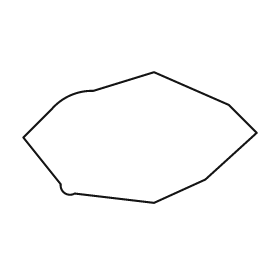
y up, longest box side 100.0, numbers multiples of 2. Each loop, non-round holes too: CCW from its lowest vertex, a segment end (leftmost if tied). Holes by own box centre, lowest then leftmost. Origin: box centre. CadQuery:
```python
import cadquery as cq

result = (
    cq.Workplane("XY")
    .moveTo(6.0, -28.0)
    .lineTo(28.0, -18.0)
    .lineTo(50.0, 2.0)
    .lineTo(38.0, 14.0)
    .lineTo(6.0, 28.0)
    .lineTo(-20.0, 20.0)
    .threePointArc((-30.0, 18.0), (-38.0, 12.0))
    .lineTo(-50.0, 0.0)
    .lineTo(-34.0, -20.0)
    .threePointArc((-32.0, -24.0), (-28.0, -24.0))
    .close()
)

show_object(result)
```